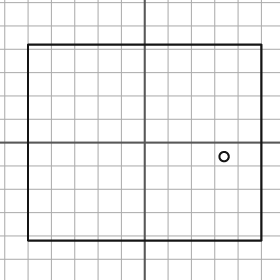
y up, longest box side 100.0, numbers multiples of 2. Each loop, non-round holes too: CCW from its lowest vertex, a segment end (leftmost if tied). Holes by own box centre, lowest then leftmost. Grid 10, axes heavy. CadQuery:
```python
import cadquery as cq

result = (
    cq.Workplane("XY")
    .moveTo(-50.0, -42.0)
    .lineTo(50.0, -42.0)
    .lineTo(50.0, 42.0)
    .lineTo(-50.0, 42.0)
    .close()
    .moveTo(34.0, -6.0)
    .circle(2.0)
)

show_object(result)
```